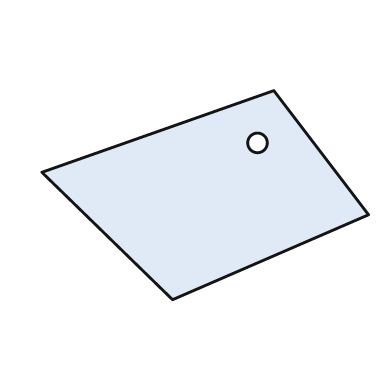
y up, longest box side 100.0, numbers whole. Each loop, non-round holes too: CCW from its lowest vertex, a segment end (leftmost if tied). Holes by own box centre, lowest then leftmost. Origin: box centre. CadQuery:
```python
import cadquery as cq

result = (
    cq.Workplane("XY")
    .moveTo(-10.0, -32.0)
    .lineTo(50.0, -6.0)
    .lineTo(21.0, 32.0)
    .lineTo(-50.0, 7.0)
    .close()
    .moveTo(16.0, 16.0)
    .circle(3.0)
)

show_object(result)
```